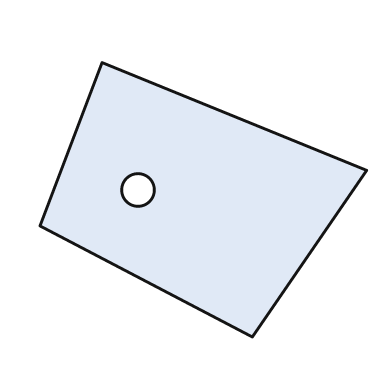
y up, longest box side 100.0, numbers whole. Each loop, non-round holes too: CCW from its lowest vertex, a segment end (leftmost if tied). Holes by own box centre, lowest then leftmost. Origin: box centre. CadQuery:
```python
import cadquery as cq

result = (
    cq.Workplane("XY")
    .moveTo(15.0, -42.0)
    .lineTo(50.0, 9.0)
    .lineTo(-31.0, 42.0)
    .lineTo(-50.0, -8.0)
    .close()
    .moveTo(-20.0, 3.0)
    .circle(5.0)
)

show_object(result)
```